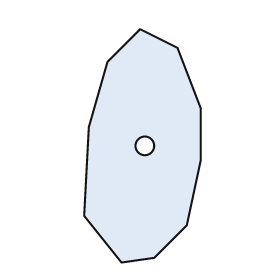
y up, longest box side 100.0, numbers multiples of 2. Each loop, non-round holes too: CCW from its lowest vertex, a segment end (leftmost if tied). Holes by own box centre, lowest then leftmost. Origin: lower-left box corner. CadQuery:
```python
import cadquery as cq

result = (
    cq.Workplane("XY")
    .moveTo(16.0, 0.0)
    .lineTo(30.0, 2.0)
    .lineTo(44.0, 16.0)
    .lineTo(50.0, 44.0)
    .lineTo(50.0, 66.0)
    .lineTo(40.0, 92.0)
    .lineTo(24.0, 100.0)
    .lineTo(10.0, 86.0)
    .lineTo(2.0, 58.0)
    .lineTo(0.0, 20.0)
    .close()
    .moveTo(26.0, 50.0)
    .circle(4.0)
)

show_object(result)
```